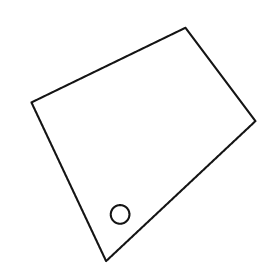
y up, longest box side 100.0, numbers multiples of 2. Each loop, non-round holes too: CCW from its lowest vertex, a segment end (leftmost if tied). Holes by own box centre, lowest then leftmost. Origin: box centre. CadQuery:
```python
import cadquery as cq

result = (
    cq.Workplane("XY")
    .moveTo(-16.0, -50.0)
    .lineTo(48.0, 10.0)
    .lineTo(18.0, 50.0)
    .lineTo(-48.0, 18.0)
    .close()
    .moveTo(-10.0, -30.0)
    .circle(4.0)
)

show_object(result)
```